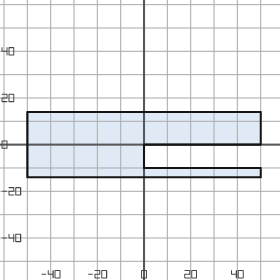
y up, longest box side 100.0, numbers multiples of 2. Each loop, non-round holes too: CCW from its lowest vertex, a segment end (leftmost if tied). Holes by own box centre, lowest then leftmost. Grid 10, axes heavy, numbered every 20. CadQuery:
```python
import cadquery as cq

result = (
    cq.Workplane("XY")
    .moveTo(-50.0, -14.0)
    .lineTo(50.0, -14.0)
    .lineTo(50.0, -10.0)
    .lineTo(0.0, -10.0)
    .lineTo(0.0, 0.0)
    .lineTo(50.0, 0.0)
    .lineTo(50.0, 14.0)
    .lineTo(-50.0, 14.0)
    .close()
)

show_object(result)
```